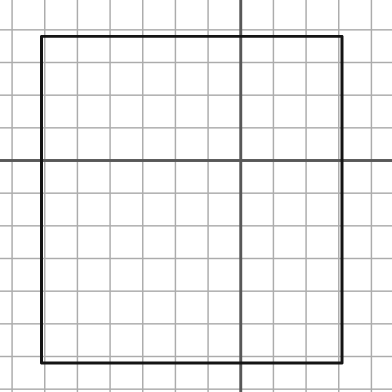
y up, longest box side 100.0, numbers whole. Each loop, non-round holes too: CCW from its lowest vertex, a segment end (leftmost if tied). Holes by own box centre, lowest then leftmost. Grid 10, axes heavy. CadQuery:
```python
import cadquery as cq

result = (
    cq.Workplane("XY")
    .moveTo(-61.0, -62.0)
    .lineTo(31.0, -62.0)
    .lineTo(31.0, 38.0)
    .lineTo(-61.0, 38.0)
    .close()
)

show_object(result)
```